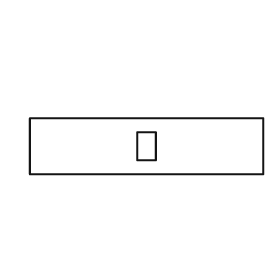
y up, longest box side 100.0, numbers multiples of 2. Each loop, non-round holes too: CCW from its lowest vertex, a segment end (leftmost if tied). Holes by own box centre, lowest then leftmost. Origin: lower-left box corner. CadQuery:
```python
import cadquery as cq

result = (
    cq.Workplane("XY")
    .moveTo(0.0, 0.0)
    .lineTo(100.0, 0.0)
    .lineTo(100.0, 24.0)
    .lineTo(0.0, 24.0)
    .close()
    .moveTo(46.0, 6.0)
    .lineTo(54.0, 6.0)
    .lineTo(54.0, 18.0)
    .lineTo(46.0, 18.0)
    .close()
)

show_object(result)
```